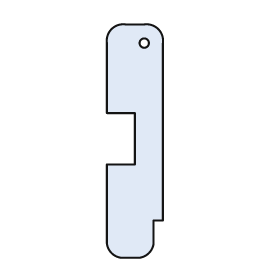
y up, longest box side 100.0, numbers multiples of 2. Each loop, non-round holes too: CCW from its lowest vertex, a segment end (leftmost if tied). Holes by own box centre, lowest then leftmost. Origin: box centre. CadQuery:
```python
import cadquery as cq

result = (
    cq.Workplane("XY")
    .moveTo(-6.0, -50.0)
    .lineTo(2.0, -50.0)
    .threePointArc((6.0, -48.0), (8.0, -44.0))
    .lineTo(8.0, -34.0)
    .lineTo(12.0, -34.0)
    .lineTo(12.0, 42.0)
    .threePointArc((10.0, 48.0), (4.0, 50.0))
    .lineTo(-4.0, 50.0)
    .threePointArc((-10.0, 48.0), (-12.0, 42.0))
    .lineTo(-12.0, 12.0)
    .lineTo(0.0, 12.0)
    .lineTo(0.0, -10.0)
    .lineTo(-12.0, -10.0)
    .lineTo(-12.0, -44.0)
    .threePointArc((-10.0, -48.0), (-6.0, -50.0))
    .close()
    .moveTo(4.0, 42.0)
    .circle(2.0)
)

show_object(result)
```